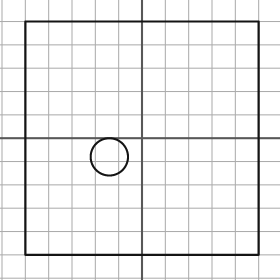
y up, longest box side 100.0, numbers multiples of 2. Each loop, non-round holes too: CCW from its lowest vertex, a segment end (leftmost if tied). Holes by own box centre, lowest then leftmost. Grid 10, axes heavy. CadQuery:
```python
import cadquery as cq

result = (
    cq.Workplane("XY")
    .moveTo(-50.0, -50.0)
    .lineTo(50.0, -50.0)
    .lineTo(50.0, 50.0)
    .lineTo(-50.0, 50.0)
    .close()
    .moveTo(-14.0, -8.0)
    .circle(8.0)
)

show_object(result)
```